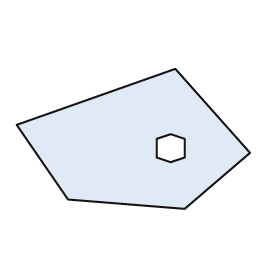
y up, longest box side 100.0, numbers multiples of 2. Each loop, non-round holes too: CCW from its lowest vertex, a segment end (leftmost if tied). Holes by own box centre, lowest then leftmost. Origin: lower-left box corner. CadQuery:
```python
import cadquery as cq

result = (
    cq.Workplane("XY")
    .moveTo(72.0, 0.0)
    .lineTo(100.0, 24.0)
    .lineTo(68.0, 60.0)
    .lineTo(0.0, 36.0)
    .lineTo(22.0, 4.0)
    .close()
    .moveTo(66.0, 20.0)
    .lineTo(72.0, 22.0)
    .lineTo(72.0, 30.0)
    .lineTo(66.0, 32.0)
    .lineTo(60.0, 30.0)
    .lineTo(60.0, 22.0)
    .close()
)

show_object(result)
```